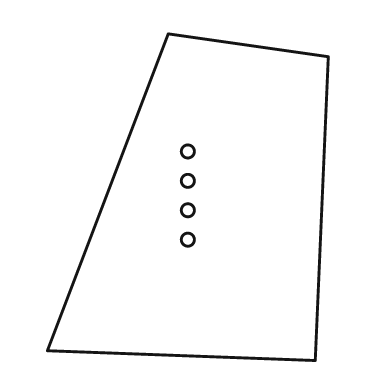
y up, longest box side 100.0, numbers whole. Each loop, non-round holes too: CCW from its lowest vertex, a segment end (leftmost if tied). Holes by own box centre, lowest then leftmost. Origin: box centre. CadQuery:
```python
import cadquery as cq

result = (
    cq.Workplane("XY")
    .moveTo(39.0, -50.0)
    .lineTo(43.0, 43.0)
    .lineTo(-6.0, 50.0)
    .lineTo(-43.0, -47.0)
    .close()
    .moveTo(0.0, -13.0)
    .circle(2.0)
    .moveTo(0.0, -4.0)
    .circle(2.0)
    .moveTo(0.0, 5.0)
    .circle(2.0)
    .moveTo(0.0, 14.0)
    .circle(2.0)
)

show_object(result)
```